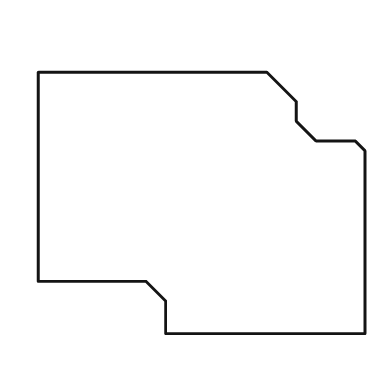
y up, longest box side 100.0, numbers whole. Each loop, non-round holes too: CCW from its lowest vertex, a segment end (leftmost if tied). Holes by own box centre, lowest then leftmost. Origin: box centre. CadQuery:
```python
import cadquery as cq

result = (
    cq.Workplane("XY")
    .moveTo(-11.0, -40.0)
    .lineTo(50.0, -40.0)
    .lineTo(50.0, 16.0)
    .lineTo(47.0, 19.0)
    .lineTo(35.0, 19.0)
    .lineTo(29.0, 25.0)
    .lineTo(29.0, 31.0)
    .lineTo(20.0, 40.0)
    .lineTo(-50.0, 40.0)
    .lineTo(-50.0, -24.0)
    .lineTo(-17.0, -24.0)
    .lineTo(-11.0, -30.0)
    .close()
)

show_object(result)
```